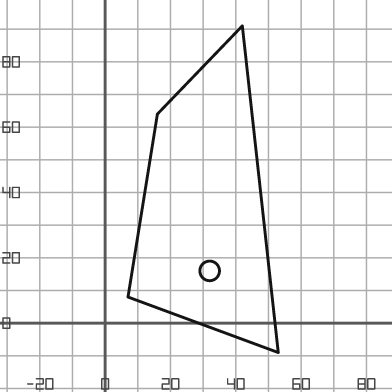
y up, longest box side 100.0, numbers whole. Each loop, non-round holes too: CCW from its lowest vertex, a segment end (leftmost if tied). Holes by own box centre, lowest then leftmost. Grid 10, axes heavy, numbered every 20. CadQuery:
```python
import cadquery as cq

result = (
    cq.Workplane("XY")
    .moveTo(53.0, -9.0)
    .lineTo(42.0, 91.0)
    .lineTo(16.0, 64.0)
    .lineTo(7.0, 8.0)
    .close()
    .moveTo(32.0, 16.0)
    .circle(3.0)
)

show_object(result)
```